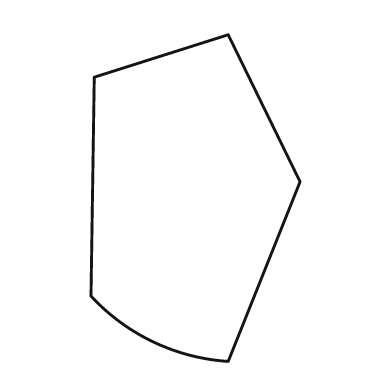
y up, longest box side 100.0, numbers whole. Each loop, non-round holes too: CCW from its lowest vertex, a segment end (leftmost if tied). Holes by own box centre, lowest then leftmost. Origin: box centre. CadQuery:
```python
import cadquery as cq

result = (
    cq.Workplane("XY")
    .moveTo(10.0, -50.0)
    .lineTo(32.0, 5.0)
    .lineTo(10.0, 50.0)
    .lineTo(-31.0, 37.0)
    .lineTo(-32.0, -30.0)
    .threePointArc((-13.0, -44.0), (10.0, -50.0))
    .close()
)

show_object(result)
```